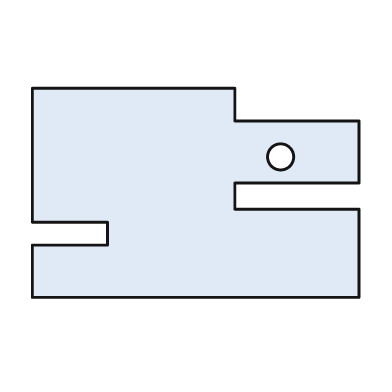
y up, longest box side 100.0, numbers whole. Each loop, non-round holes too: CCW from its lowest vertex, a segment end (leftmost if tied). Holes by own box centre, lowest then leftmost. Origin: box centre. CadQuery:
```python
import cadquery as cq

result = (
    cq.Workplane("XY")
    .moveTo(-50.0, -32.0)
    .lineTo(50.0, -32.0)
    .lineTo(50.0, -5.0)
    .lineTo(12.0, -5.0)
    .lineTo(12.0, 3.0)
    .lineTo(50.0, 3.0)
    .lineTo(50.0, 22.0)
    .lineTo(12.0, 22.0)
    .lineTo(12.0, 32.0)
    .lineTo(-50.0, 32.0)
    .lineTo(-50.0, -9.0)
    .lineTo(-27.0, -9.0)
    .lineTo(-27.0, -16.0)
    .lineTo(-50.0, -16.0)
    .close()
    .moveTo(26.0, 11.0)
    .circle(4.0)
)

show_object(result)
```